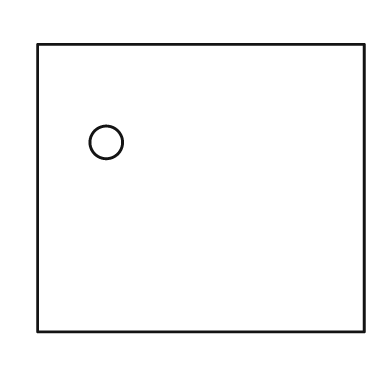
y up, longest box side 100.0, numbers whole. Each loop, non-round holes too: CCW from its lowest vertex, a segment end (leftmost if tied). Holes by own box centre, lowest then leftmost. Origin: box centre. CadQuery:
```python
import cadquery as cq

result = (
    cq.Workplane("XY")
    .moveTo(-50.0, -44.0)
    .lineTo(50.0, -44.0)
    .lineTo(50.0, 44.0)
    .lineTo(-50.0, 44.0)
    .close()
    .moveTo(-29.0, 14.0)
    .circle(5.0)
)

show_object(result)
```